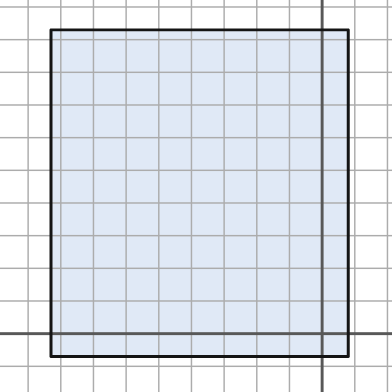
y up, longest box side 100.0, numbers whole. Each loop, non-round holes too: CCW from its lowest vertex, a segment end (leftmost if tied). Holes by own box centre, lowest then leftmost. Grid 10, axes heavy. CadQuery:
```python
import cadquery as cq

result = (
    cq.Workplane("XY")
    .moveTo(-83.0, -7.0)
    .lineTo(8.0, -7.0)
    .lineTo(8.0, 93.0)
    .lineTo(-83.0, 93.0)
    .close()
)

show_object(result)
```